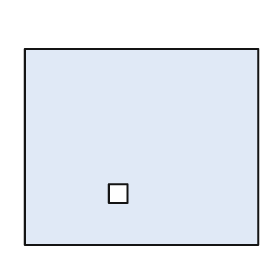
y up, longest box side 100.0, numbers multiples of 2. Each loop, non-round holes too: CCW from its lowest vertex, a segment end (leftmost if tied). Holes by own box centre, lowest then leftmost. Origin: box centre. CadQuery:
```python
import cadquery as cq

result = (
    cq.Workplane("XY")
    .moveTo(-50.0, -42.0)
    .lineTo(50.0, -42.0)
    .lineTo(50.0, 42.0)
    .lineTo(-50.0, 42.0)
    .close()
    .moveTo(-14.0, -24.0)
    .lineTo(-6.0, -24.0)
    .lineTo(-6.0, -16.0)
    .lineTo(-14.0, -16.0)
    .close()
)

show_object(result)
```